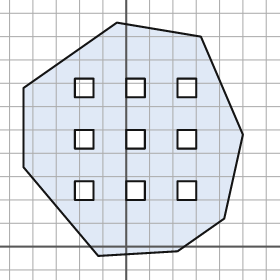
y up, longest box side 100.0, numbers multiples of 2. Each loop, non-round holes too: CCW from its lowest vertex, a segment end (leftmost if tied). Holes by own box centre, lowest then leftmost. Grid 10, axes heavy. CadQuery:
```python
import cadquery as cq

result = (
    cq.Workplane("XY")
    .moveTo(-12.0, -4.0)
    .lineTo(22.0, -2.0)
    .lineTo(42.0, 12.0)
    .lineTo(50.0, 48.0)
    .lineTo(32.0, 90.0)
    .lineTo(-4.0, 96.0)
    .lineTo(-44.0, 68.0)
    .lineTo(-44.0, 34.0)
    .close()
    .moveTo(-22.0, 20.0)
    .lineTo(-14.0, 20.0)
    .lineTo(-14.0, 28.0)
    .lineTo(-22.0, 28.0)
    .close()
    .moveTo(0.0, 20.0)
    .lineTo(8.0, 20.0)
    .lineTo(8.0, 28.0)
    .lineTo(0.0, 28.0)
    .close()
    .moveTo(22.0, 20.0)
    .lineTo(30.0, 20.0)
    .lineTo(30.0, 28.0)
    .lineTo(22.0, 28.0)
    .close()
    .moveTo(-22.0, 42.0)
    .lineTo(-14.0, 42.0)
    .lineTo(-14.0, 50.0)
    .lineTo(-22.0, 50.0)
    .close()
    .moveTo(0.0, 42.0)
    .lineTo(8.0, 42.0)
    .lineTo(8.0, 50.0)
    .lineTo(0.0, 50.0)
    .close()
    .moveTo(22.0, 42.0)
    .lineTo(30.0, 42.0)
    .lineTo(30.0, 50.0)
    .lineTo(22.0, 50.0)
    .close()
    .moveTo(-22.0, 64.0)
    .lineTo(-14.0, 64.0)
    .lineTo(-14.0, 72.0)
    .lineTo(-22.0, 72.0)
    .close()
    .moveTo(0.0, 64.0)
    .lineTo(8.0, 64.0)
    .lineTo(8.0, 72.0)
    .lineTo(0.0, 72.0)
    .close()
    .moveTo(22.0, 64.0)
    .lineTo(30.0, 64.0)
    .lineTo(30.0, 72.0)
    .lineTo(22.0, 72.0)
    .close()
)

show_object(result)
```